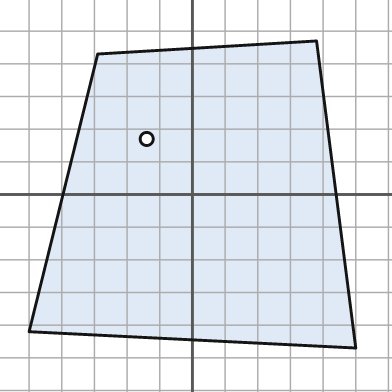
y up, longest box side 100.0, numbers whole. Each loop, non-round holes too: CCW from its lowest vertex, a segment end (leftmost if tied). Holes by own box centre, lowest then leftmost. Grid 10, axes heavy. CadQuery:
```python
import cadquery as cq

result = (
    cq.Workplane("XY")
    .moveTo(50.0, -47.0)
    .lineTo(38.0, 47.0)
    .lineTo(-29.0, 43.0)
    .lineTo(-50.0, -42.0)
    .close()
    .moveTo(-14.0, 17.0)
    .circle(2.0)
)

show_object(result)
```